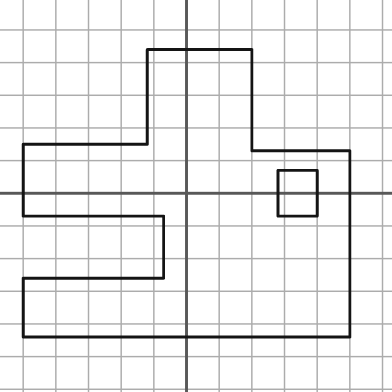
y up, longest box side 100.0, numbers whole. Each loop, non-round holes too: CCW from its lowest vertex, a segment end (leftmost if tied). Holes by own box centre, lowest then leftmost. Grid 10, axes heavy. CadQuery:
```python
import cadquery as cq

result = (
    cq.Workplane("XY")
    .moveTo(-50.0, -44.0)
    .lineTo(50.0, -44.0)
    .lineTo(50.0, 13.0)
    .lineTo(20.0, 13.0)
    .lineTo(20.0, 44.0)
    .lineTo(-12.0, 44.0)
    .lineTo(-12.0, 15.0)
    .lineTo(-50.0, 15.0)
    .lineTo(-50.0, -7.0)
    .lineTo(-7.0, -7.0)
    .lineTo(-7.0, -26.0)
    .lineTo(-50.0, -26.0)
    .close()
    .moveTo(28.0, -7.0)
    .lineTo(40.0, -7.0)
    .lineTo(40.0, 7.0)
    .lineTo(28.0, 7.0)
    .close()
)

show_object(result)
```